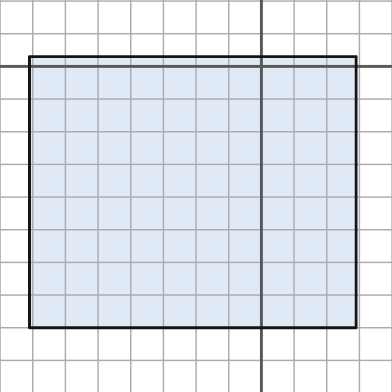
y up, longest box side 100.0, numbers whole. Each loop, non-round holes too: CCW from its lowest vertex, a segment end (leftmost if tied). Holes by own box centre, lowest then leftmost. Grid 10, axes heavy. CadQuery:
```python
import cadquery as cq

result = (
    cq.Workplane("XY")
    .moveTo(-71.0, -80.0)
    .lineTo(29.0, -80.0)
    .lineTo(29.0, 3.0)
    .lineTo(-71.0, 3.0)
    .close()
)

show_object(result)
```